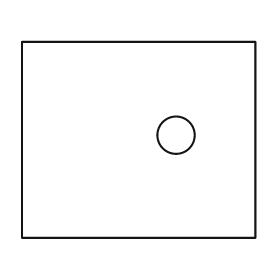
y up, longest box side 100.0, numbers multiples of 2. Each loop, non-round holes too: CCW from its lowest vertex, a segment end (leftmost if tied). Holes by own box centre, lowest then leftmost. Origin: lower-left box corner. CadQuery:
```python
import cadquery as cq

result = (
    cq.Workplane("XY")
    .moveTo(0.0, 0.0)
    .lineTo(100.0, 0.0)
    .lineTo(100.0, 84.0)
    .lineTo(0.0, 84.0)
    .close()
    .moveTo(66.0, 44.0)
    .circle(8.0)
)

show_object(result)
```